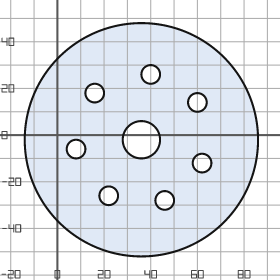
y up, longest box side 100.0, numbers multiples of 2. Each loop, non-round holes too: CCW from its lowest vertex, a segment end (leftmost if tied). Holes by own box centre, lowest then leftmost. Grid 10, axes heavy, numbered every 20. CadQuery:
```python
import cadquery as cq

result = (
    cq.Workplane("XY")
    .moveTo(36.0, -2.0)
    .circle(50.0)
    .moveTo(46.0, -28.0)
    .circle(4.0)
    .moveTo(22.0, -26.0)
    .circle(4.0)
    .moveTo(62.0, -12.0)
    .circle(4.0)
    .moveTo(8.0, -6.0)
    .circle(4.0)
    .moveTo(36.0, -2.0)
    .circle(8.0)
    .moveTo(60.0, 14.0)
    .circle(4.0)
    .moveTo(16.0, 18.0)
    .circle(4.0)
    .moveTo(40.0, 26.0)
    .circle(4.0)
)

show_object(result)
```